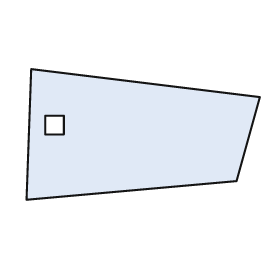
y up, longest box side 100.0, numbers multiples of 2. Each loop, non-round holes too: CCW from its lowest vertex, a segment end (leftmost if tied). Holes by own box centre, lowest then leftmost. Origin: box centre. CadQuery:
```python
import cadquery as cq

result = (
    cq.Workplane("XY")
    .moveTo(-50.0, -28.0)
    .lineTo(40.0, -20.0)
    .lineTo(50.0, 16.0)
    .lineTo(-48.0, 28.0)
    .close()
    .moveTo(-42.0, 0.0)
    .lineTo(-34.0, 0.0)
    .lineTo(-34.0, 8.0)
    .lineTo(-42.0, 8.0)
    .close()
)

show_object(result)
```